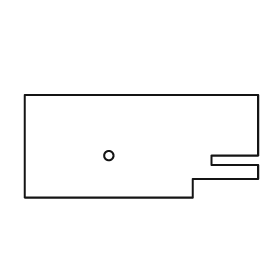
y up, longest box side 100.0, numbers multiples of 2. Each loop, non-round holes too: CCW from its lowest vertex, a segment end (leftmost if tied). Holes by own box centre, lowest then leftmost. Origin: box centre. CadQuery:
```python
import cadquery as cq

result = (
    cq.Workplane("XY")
    .moveTo(-50.0, -22.0)
    .lineTo(22.0, -22.0)
    .lineTo(22.0, -14.0)
    .lineTo(50.0, -14.0)
    .lineTo(50.0, -8.0)
    .lineTo(30.0, -8.0)
    .lineTo(30.0, -4.0)
    .lineTo(50.0, -4.0)
    .lineTo(50.0, 22.0)
    .lineTo(-50.0, 22.0)
    .close()
    .moveTo(-14.0, -4.0)
    .circle(2.0)
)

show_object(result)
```